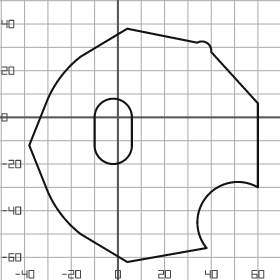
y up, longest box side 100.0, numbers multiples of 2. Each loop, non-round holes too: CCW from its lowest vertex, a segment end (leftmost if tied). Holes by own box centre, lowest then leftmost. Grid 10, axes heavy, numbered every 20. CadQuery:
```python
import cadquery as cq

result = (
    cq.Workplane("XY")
    .moveTo(4.0, -62.0)
    .lineTo(38.0, -56.0)
    .threePointArc((38.0, -34.0), (60.0, -30.0))
    .lineTo(60.0, 6.0)
    .lineTo(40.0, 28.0)
    .threePointArc((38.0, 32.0), (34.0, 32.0))
    .lineTo(4.0, 38.0)
    .lineTo(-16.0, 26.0)
    .threePointArc((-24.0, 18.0), (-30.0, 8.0))
    .lineTo(-38.0, -12.0)
    .lineTo(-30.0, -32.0)
    .threePointArc((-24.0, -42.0), (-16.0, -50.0))
    .close()
    .moveTo(-10.0, -12.0)
    .threePointArc((-2.0, -20.0), (6.0, -12.0))
    .lineTo(6.0, 0.0)
    .threePointArc((-2.0, 8.0), (-10.0, 0.0))
    .close()
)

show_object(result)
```